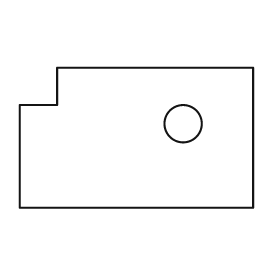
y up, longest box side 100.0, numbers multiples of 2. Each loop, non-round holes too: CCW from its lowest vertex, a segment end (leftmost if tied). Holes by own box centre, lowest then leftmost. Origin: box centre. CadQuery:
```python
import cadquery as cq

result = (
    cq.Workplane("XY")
    .moveTo(-50.0, -30.0)
    .lineTo(50.0, -30.0)
    .lineTo(50.0, 30.0)
    .lineTo(-34.0, 30.0)
    .lineTo(-34.0, 14.0)
    .lineTo(-50.0, 14.0)
    .close()
    .moveTo(20.0, 6.0)
    .circle(8.0)
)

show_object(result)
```